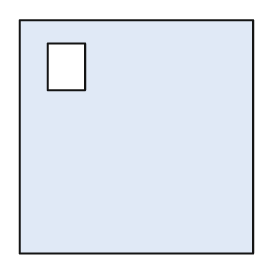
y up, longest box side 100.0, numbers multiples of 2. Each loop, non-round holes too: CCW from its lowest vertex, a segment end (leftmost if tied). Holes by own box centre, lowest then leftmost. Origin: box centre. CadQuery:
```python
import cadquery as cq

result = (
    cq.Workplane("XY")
    .moveTo(-50.0, -50.0)
    .lineTo(50.0, -50.0)
    .lineTo(50.0, 50.0)
    .lineTo(-50.0, 50.0)
    .close()
    .moveTo(-38.0, 20.0)
    .lineTo(-22.0, 20.0)
    .lineTo(-22.0, 40.0)
    .lineTo(-38.0, 40.0)
    .close()
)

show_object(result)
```